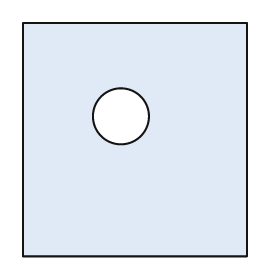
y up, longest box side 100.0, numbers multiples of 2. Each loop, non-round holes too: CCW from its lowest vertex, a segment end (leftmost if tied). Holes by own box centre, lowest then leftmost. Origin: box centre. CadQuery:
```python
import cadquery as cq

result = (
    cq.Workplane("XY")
    .moveTo(-48.0, -50.0)
    .lineTo(48.0, -50.0)
    .lineTo(48.0, 50.0)
    .lineTo(-48.0, 50.0)
    .close()
    .moveTo(-6.0, 10.0)
    .circle(12.0)
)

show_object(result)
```